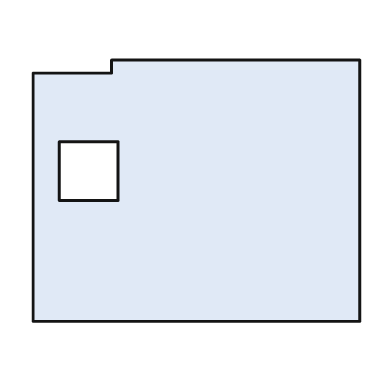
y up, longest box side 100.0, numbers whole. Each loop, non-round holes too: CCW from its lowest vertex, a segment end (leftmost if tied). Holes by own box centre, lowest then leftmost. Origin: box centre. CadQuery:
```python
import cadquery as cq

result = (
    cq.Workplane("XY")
    .moveTo(-50.0, -40.0)
    .lineTo(50.0, -40.0)
    .lineTo(50.0, 40.0)
    .lineTo(-26.0, 40.0)
    .lineTo(-26.0, 36.0)
    .lineTo(-50.0, 36.0)
    .close()
    .moveTo(-42.0, -3.0)
    .lineTo(-24.0, -3.0)
    .lineTo(-24.0, 15.0)
    .lineTo(-42.0, 15.0)
    .close()
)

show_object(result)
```